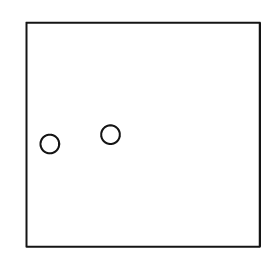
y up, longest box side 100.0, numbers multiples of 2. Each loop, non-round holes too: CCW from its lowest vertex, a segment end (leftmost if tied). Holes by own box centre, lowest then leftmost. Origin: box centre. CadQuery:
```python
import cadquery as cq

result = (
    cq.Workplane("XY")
    .moveTo(-50.0, -48.0)
    .lineTo(50.0, -48.0)
    .lineTo(50.0, 48.0)
    .lineTo(-50.0, 48.0)
    .close()
    .moveTo(-40.0, -4.0)
    .circle(4.0)
    .moveTo(-14.0, 0.0)
    .circle(4.0)
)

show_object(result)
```